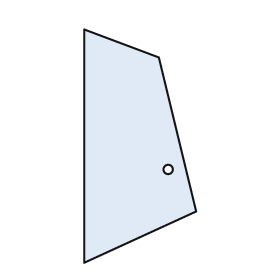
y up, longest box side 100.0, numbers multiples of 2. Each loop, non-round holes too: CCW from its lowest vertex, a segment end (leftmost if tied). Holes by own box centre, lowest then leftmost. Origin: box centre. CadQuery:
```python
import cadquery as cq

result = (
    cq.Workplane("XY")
    .moveTo(-24.0, -50.0)
    .lineTo(24.0, -28.0)
    .lineTo(8.0, 38.0)
    .lineTo(-24.0, 50.0)
    .close()
    .moveTo(12.0, -10.0)
    .circle(2.0)
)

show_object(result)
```